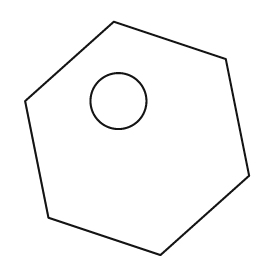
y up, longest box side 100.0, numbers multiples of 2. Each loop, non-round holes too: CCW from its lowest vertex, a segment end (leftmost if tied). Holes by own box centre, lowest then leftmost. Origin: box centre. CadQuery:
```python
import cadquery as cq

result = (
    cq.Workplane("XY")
    .moveTo(10.0, -50.0)
    .lineTo(48.0, -16.0)
    .lineTo(38.0, 34.0)
    .lineTo(-10.0, 50.0)
    .lineTo(-48.0, 16.0)
    .lineTo(-38.0, -34.0)
    .close()
    .moveTo(-8.0, 16.0)
    .circle(12.0)
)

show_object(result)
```